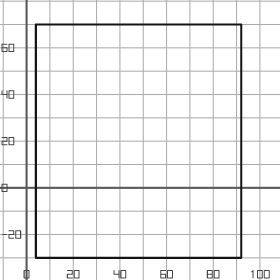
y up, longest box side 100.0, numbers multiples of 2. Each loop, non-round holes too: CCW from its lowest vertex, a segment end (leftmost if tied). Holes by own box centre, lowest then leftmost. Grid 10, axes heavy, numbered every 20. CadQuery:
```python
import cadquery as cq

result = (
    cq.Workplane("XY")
    .moveTo(4.0, -30.0)
    .lineTo(92.0, -30.0)
    .lineTo(92.0, 70.0)
    .lineTo(4.0, 70.0)
    .close()
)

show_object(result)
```